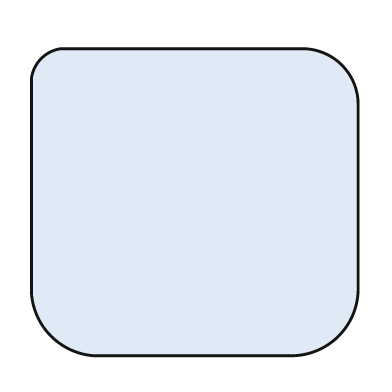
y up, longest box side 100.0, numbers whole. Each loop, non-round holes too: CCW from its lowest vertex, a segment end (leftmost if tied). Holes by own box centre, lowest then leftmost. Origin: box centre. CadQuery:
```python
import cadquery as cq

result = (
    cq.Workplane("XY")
    .moveTo(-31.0, -47.0)
    .lineTo(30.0, -47.0)
    .threePointArc((44.0, -41.0), (50.0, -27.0))
    .lineTo(50.0, 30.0)
    .threePointArc((45.0, 42.0), (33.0, 47.0))
    .lineTo(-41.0, 47.0)
    .threePointArc((-47.0, 44.0), (-50.0, 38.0))
    .lineTo(-50.0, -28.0)
    .threePointArc((-44.0, -41.0), (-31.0, -47.0))
    .close()
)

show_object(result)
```